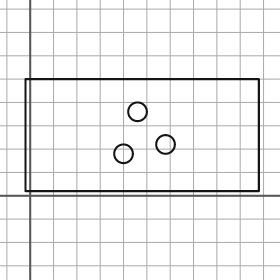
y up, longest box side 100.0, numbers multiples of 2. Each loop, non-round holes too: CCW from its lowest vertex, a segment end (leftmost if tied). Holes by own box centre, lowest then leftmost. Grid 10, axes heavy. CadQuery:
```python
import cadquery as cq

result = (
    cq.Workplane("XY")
    .moveTo(-2.0, 2.0)
    .lineTo(98.0, 2.0)
    .lineTo(98.0, 50.0)
    .lineTo(-2.0, 50.0)
    .close()
    .moveTo(40.0, 18.0)
    .circle(4.0)
    .moveTo(58.0, 22.0)
    .circle(4.0)
    .moveTo(46.0, 36.0)
    .circle(4.0)
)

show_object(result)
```